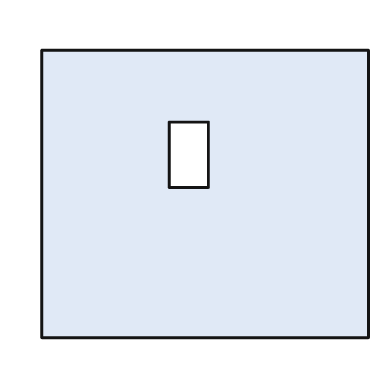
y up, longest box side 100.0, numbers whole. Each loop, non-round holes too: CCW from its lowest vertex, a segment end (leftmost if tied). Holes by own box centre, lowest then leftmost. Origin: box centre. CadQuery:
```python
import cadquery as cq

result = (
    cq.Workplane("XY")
    .moveTo(-50.0, -44.0)
    .lineTo(50.0, -44.0)
    .lineTo(50.0, 44.0)
    .lineTo(-50.0, 44.0)
    .close()
    .moveTo(-11.0, 2.0)
    .lineTo(1.0, 2.0)
    .lineTo(1.0, 22.0)
    .lineTo(-11.0, 22.0)
    .close()
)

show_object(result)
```